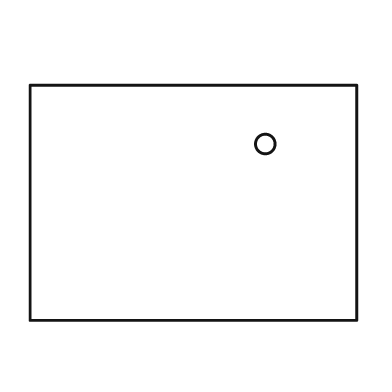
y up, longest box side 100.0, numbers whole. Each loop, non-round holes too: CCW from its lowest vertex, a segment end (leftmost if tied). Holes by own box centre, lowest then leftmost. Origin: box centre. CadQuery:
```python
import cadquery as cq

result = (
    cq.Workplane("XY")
    .moveTo(-50.0, -36.0)
    .lineTo(50.0, -36.0)
    .lineTo(50.0, 36.0)
    .lineTo(-50.0, 36.0)
    .close()
    .moveTo(22.0, 18.0)
    .circle(3.0)
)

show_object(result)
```